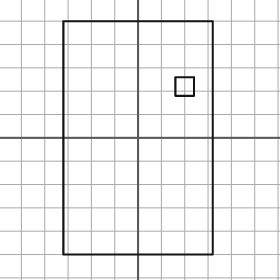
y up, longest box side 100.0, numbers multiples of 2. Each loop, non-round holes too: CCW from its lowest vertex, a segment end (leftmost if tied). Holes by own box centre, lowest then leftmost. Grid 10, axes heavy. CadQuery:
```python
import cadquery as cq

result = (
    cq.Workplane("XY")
    .moveTo(-32.0, -50.0)
    .lineTo(32.0, -50.0)
    .lineTo(32.0, 50.0)
    .lineTo(-32.0, 50.0)
    .close()
    .moveTo(16.0, 18.0)
    .lineTo(24.0, 18.0)
    .lineTo(24.0, 26.0)
    .lineTo(16.0, 26.0)
    .close()
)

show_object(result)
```